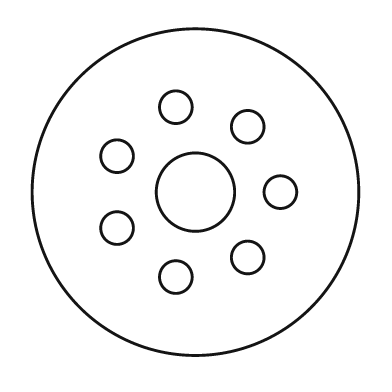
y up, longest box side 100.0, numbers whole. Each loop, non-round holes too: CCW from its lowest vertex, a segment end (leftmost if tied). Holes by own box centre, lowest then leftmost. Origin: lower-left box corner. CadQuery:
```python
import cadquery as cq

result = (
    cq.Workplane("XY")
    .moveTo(50.0, 50.0)
    .circle(50.0)
    .moveTo(44.0, 24.0)
    .circle(5.0)
    .moveTo(66.0, 30.0)
    .circle(5.0)
    .moveTo(26.0, 39.0)
    .circle(5.0)
    .moveTo(50.0, 50.0)
    .circle(12.0)
    .moveTo(76.0, 50.0)
    .circle(5.0)
    .moveTo(26.0, 61.0)
    .circle(5.0)
    .moveTo(66.0, 70.0)
    .circle(5.0)
    .moveTo(44.0, 76.0)
    .circle(5.0)
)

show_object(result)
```